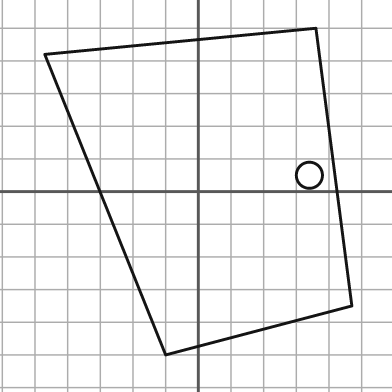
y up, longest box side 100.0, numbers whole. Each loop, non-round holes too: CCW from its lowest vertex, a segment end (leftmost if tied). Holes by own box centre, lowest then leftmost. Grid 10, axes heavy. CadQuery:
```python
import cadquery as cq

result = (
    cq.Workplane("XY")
    .moveTo(-10.0, -50.0)
    .lineTo(47.0, -35.0)
    .lineTo(36.0, 50.0)
    .lineTo(-47.0, 42.0)
    .close()
    .moveTo(34.0, 5.0)
    .circle(4.0)
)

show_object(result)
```